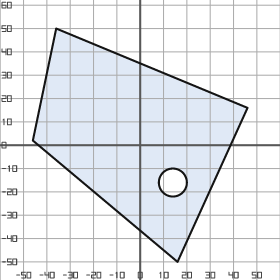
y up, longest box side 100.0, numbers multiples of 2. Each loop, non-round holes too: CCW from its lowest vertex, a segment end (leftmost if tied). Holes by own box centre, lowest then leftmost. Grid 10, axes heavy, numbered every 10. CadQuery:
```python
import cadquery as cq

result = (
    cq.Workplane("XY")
    .moveTo(16.0, -50.0)
    .lineTo(46.0, 16.0)
    .lineTo(-36.0, 50.0)
    .lineTo(-46.0, 2.0)
    .close()
    .moveTo(14.0, -16.0)
    .circle(6.0)
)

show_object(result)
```